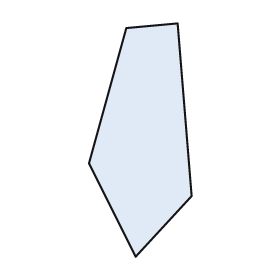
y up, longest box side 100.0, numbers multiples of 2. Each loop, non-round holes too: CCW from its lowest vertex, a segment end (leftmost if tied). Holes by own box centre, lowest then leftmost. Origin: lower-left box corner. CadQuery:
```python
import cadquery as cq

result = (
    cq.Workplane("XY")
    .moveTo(20.0, 0.0)
    .lineTo(44.0, 26.0)
    .lineTo(38.0, 100.0)
    .lineTo(16.0, 98.0)
    .lineTo(0.0, 40.0)
    .close()
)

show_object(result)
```